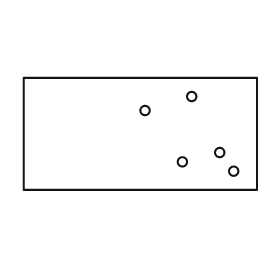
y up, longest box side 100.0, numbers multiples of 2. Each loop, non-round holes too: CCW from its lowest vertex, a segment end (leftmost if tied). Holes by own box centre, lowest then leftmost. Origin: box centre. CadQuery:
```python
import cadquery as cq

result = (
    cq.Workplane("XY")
    .moveTo(-50.0, -24.0)
    .lineTo(50.0, -24.0)
    .lineTo(50.0, 24.0)
    .lineTo(-50.0, 24.0)
    .close()
    .moveTo(40.0, -16.0)
    .circle(2.0)
    .moveTo(18.0, -12.0)
    .circle(2.0)
    .moveTo(34.0, -8.0)
    .circle(2.0)
    .moveTo(2.0, 10.0)
    .circle(2.0)
    .moveTo(22.0, 16.0)
    .circle(2.0)
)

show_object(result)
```